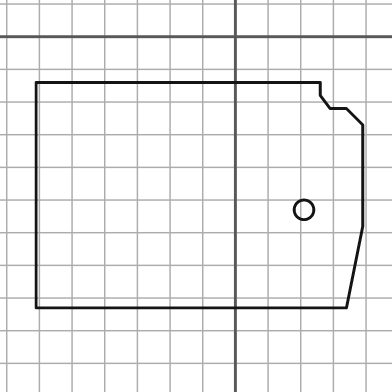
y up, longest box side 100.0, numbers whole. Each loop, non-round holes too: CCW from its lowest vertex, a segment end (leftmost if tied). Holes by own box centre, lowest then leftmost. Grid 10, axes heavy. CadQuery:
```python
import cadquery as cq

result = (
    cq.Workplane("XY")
    .moveTo(-61.0, -83.0)
    .lineTo(34.0, -83.0)
    .lineTo(39.0, -58.0)
    .lineTo(39.0, -27.0)
    .lineTo(34.0, -22.0)
    .lineTo(29.0, -22.0)
    .lineTo(26.0, -18.0)
    .lineTo(26.0, -14.0)
    .lineTo(-61.0, -14.0)
    .close()
    .moveTo(21.0, -53.0)
    .circle(3.0)
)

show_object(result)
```